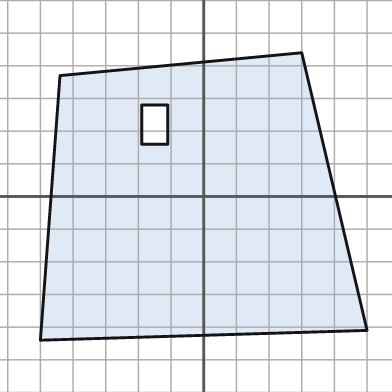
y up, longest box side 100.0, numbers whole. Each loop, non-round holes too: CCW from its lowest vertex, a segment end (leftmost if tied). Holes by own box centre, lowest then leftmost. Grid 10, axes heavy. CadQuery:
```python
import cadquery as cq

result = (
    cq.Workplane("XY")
    .moveTo(-50.0, -44.0)
    .lineTo(50.0, -41.0)
    .lineTo(30.0, 44.0)
    .lineTo(-44.0, 37.0)
    .close()
    .moveTo(-19.0, 16.0)
    .lineTo(-11.0, 16.0)
    .lineTo(-11.0, 28.0)
    .lineTo(-19.0, 28.0)
    .close()
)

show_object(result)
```